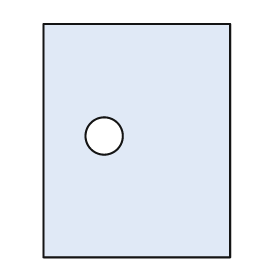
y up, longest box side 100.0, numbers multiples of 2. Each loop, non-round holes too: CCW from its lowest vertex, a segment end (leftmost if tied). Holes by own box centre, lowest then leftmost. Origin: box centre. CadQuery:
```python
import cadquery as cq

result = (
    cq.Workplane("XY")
    .moveTo(-40.0, -50.0)
    .lineTo(40.0, -50.0)
    .lineTo(40.0, 50.0)
    .lineTo(-40.0, 50.0)
    .close()
    .moveTo(-14.0, 2.0)
    .circle(8.0)
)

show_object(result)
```